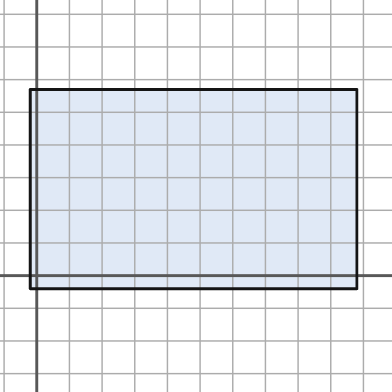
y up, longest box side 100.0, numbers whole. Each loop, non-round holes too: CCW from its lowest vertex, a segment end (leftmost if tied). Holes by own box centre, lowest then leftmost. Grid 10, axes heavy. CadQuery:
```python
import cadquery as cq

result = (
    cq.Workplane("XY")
    .moveTo(-2.0, -4.0)
    .lineTo(98.0, -4.0)
    .lineTo(98.0, 57.0)
    .lineTo(-2.0, 57.0)
    .close()
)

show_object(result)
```